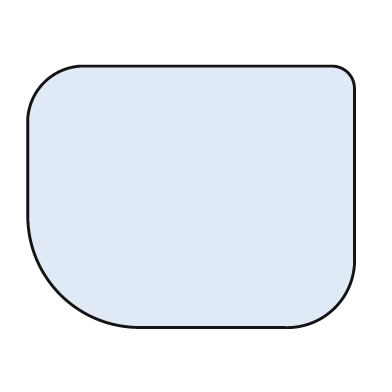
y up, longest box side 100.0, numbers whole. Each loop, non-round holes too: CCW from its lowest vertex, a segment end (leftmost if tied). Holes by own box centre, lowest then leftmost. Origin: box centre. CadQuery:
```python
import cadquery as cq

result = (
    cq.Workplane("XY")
    .moveTo(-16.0, -40.0)
    .lineTo(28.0, -40.0)
    .threePointArc((44.0, -34.0), (50.0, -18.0))
    .lineTo(50.0, 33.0)
    .threePointArc((48.0, 38.0), (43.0, 40.0))
    .lineTo(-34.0, 40.0)
    .threePointArc((-45.0, 35.0), (-50.0, 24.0))
    .lineTo(-50.0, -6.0)
    .threePointArc((-40.0, -30.0), (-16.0, -40.0))
    .close()
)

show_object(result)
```